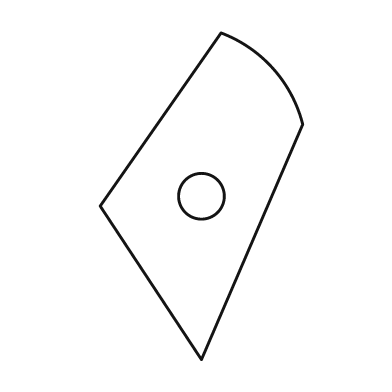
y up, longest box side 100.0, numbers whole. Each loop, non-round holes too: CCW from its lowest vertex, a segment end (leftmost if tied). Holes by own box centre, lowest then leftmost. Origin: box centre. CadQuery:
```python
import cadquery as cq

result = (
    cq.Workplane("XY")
    .moveTo(0.0, -50.0)
    .lineTo(31.0, 22.0)
    .threePointArc((22.0, 39.0), (6.0, 50.0))
    .lineTo(-31.0, -3.0)
    .close()
    .moveTo(0.0, 0.0)
    .circle(7.0)
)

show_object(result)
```